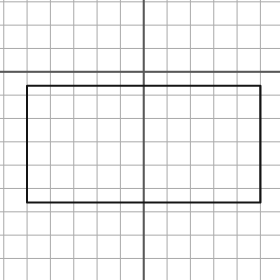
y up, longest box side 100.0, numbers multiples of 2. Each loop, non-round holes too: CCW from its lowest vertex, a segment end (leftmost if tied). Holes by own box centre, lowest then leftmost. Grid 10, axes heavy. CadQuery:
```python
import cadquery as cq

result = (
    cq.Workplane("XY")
    .moveTo(-50.0, -56.0)
    .lineTo(50.0, -56.0)
    .lineTo(50.0, -6.0)
    .lineTo(-50.0, -6.0)
    .close()
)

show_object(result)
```